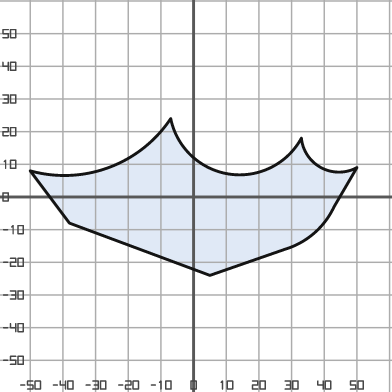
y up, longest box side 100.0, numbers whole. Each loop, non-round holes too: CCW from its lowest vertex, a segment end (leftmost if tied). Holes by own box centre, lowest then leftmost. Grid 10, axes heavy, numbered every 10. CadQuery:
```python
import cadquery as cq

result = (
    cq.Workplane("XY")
    .moveTo(5.0, -24.0)
    .lineTo(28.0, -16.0)
    .threePointArc((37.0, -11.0), (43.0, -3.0))
    .lineTo(50.0, 9.0)
    .threePointArc((39.0, 9.0), (33.0, 18.0))
    .threePointArc((11.0, 7.0), (-7.0, 24.0))
    .threePointArc((-26.0, 9.0), (-50.0, 8.0))
    .lineTo(-38.0, -8.0)
    .close()
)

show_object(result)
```